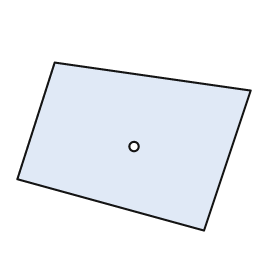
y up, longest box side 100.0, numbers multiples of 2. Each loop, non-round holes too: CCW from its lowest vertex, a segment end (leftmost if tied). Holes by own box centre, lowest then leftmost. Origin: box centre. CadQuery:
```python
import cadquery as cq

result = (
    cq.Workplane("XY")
    .moveTo(30.0, -36.0)
    .lineTo(50.0, 24.0)
    .lineTo(-34.0, 36.0)
    .lineTo(-50.0, -14.0)
    .close()
    .moveTo(0.0, 0.0)
    .circle(2.0)
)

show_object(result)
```